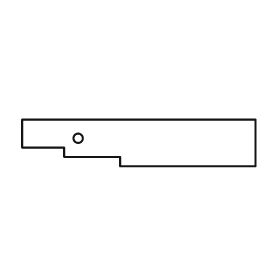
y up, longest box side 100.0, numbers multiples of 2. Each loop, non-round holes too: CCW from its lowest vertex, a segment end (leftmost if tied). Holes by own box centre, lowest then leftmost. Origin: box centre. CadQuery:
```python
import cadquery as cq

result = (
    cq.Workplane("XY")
    .moveTo(-8.0, -10.0)
    .lineTo(50.0, -10.0)
    .lineTo(50.0, 10.0)
    .lineTo(-50.0, 10.0)
    .lineTo(-50.0, -2.0)
    .lineTo(-32.0, -2.0)
    .lineTo(-32.0, -6.0)
    .lineTo(-8.0, -6.0)
    .close()
    .moveTo(-26.0, 2.0)
    .circle(2.0)
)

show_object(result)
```